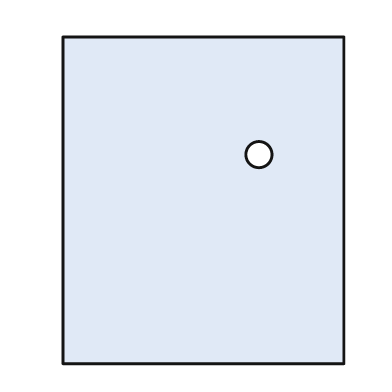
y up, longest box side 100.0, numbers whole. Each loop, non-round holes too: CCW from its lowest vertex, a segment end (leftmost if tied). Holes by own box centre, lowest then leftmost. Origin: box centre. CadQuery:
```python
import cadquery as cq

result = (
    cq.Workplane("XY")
    .moveTo(-43.0, -50.0)
    .lineTo(43.0, -50.0)
    .lineTo(43.0, 50.0)
    .lineTo(-43.0, 50.0)
    .close()
    .moveTo(17.0, 14.0)
    .circle(4.0)
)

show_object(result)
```